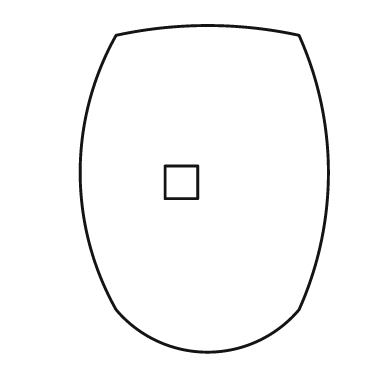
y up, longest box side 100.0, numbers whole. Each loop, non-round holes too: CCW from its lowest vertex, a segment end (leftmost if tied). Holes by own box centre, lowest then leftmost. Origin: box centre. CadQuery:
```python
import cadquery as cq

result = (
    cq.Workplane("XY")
    .moveTo(-27.0, -37.0)
    .threePointArc((1.0, -50.0), (29.0, -37.0))
    .threePointArc((38.0, 5.0), (29.0, 47.0))
    .threePointArc((1.0, 50.0), (-27.0, 47.0))
    .threePointArc((-38.0, 5.0), (-27.0, -37.0))
    .close()
    .moveTo(-12.0, -3.0)
    .lineTo(-2.0, -3.0)
    .lineTo(-2.0, 7.0)
    .lineTo(-12.0, 7.0)
    .close()
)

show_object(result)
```